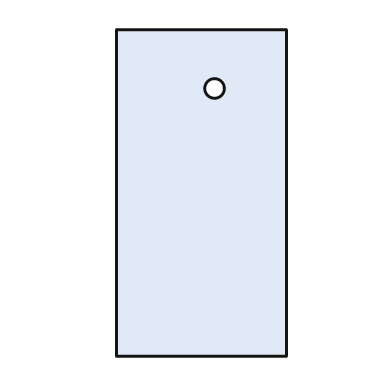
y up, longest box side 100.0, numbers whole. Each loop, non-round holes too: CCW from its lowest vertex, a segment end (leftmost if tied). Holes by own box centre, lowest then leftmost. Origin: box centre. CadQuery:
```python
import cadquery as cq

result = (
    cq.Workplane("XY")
    .moveTo(-26.0, -50.0)
    .lineTo(26.0, -50.0)
    .lineTo(26.0, 50.0)
    .lineTo(-26.0, 50.0)
    .close()
    .moveTo(4.0, 32.0)
    .circle(3.0)
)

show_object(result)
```